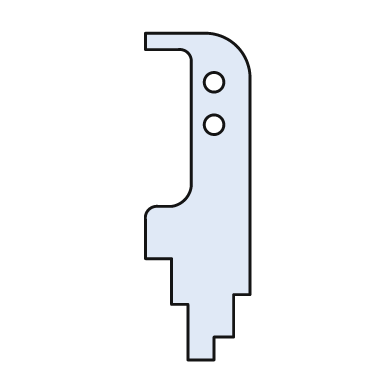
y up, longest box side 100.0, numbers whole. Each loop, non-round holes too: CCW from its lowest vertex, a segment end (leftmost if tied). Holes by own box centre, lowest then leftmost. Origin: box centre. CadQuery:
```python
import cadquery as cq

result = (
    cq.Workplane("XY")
    .moveTo(-3.0, -50.0)
    .lineTo(5.0, -50.0)
    .lineTo(5.0, -43.0)
    .lineTo(11.0, -43.0)
    .lineTo(11.0, -30.0)
    .lineTo(16.0, -30.0)
    .lineTo(16.0, 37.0)
    .threePointArc((12.0, 46.0), (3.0, 50.0))
    .lineTo(-16.0, 50.0)
    .lineTo(-16.0, 45.0)
    .lineTo(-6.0, 45.0)
    .threePointArc((-3.0, 44.0), (-2.0, 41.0))
    .lineTo(-2.0, 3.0)
    .threePointArc((-4.0, -1.0), (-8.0, -3.0))
    .lineTo(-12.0, -3.0)
    .threePointArc((-15.0, -4.0), (-16.0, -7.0))
    .lineTo(-16.0, -19.0)
    .lineTo(-8.0, -19.0)
    .lineTo(-8.0, -33.0)
    .lineTo(-3.0, -33.0)
    .close()
    .moveTo(5.0, 22.0)
    .circle(3.0)
    .moveTo(5.0, 35.0)
    .circle(3.0)
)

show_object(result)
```